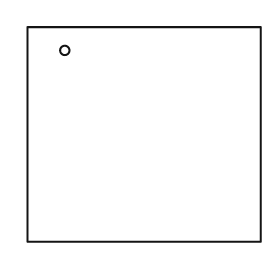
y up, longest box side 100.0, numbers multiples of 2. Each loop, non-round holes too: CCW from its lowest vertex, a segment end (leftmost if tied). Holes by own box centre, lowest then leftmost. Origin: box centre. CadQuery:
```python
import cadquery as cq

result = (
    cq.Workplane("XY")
    .moveTo(-50.0, -46.0)
    .lineTo(50.0, -46.0)
    .lineTo(50.0, 46.0)
    .lineTo(-50.0, 46.0)
    .close()
    .moveTo(-34.0, 36.0)
    .circle(2.0)
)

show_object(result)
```